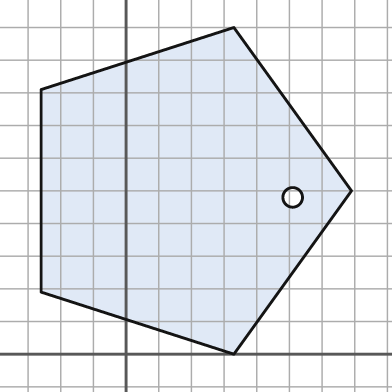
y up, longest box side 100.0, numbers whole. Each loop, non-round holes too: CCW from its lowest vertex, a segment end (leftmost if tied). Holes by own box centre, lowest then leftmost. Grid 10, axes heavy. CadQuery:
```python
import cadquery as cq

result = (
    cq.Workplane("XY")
    .moveTo(33.0, 0.0)
    .lineTo(69.0, 50.0)
    .lineTo(33.0, 100.0)
    .lineTo(-26.0, 81.0)
    .lineTo(-26.0, 19.0)
    .close()
    .moveTo(51.0, 48.0)
    .circle(3.0)
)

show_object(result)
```